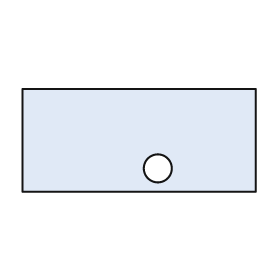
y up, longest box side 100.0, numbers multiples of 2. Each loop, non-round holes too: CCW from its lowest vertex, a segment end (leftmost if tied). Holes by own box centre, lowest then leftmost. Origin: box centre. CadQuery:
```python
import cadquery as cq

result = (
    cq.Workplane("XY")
    .moveTo(-50.0, -22.0)
    .lineTo(50.0, -22.0)
    .lineTo(50.0, 22.0)
    .lineTo(-50.0, 22.0)
    .close()
    .moveTo(8.0, -12.0)
    .circle(6.0)
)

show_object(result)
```